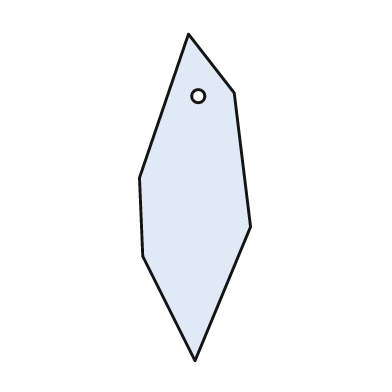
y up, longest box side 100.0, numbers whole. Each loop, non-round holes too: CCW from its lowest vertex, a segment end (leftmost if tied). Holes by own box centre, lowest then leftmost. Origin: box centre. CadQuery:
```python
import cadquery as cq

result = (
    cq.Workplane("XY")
    .moveTo(0.0, -50.0)
    .lineTo(17.0, -9.0)
    .lineTo(12.0, 32.0)
    .lineTo(-2.0, 50.0)
    .lineTo(-17.0, 6.0)
    .lineTo(-16.0, -18.0)
    .close()
    .moveTo(1.0, 31.0)
    .circle(2.0)
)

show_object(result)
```